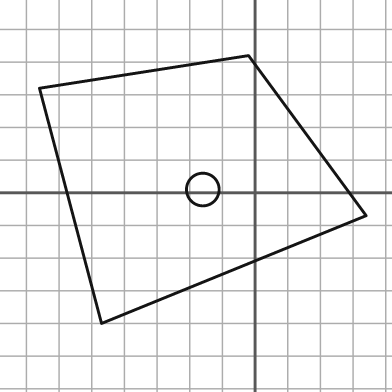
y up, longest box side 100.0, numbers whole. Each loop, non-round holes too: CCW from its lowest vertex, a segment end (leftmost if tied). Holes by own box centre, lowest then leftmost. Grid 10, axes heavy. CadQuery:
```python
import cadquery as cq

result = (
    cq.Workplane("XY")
    .moveTo(-47.0, -40.0)
    .lineTo(34.0, -7.0)
    .lineTo(-2.0, 42.0)
    .lineTo(-66.0, 32.0)
    .close()
    .moveTo(-16.0, 1.0)
    .circle(5.0)
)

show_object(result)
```